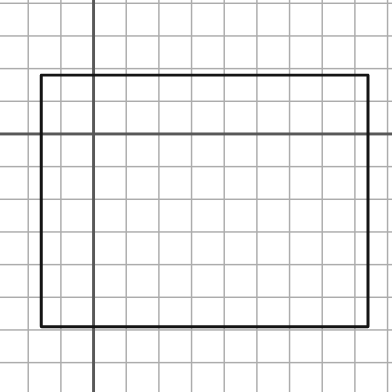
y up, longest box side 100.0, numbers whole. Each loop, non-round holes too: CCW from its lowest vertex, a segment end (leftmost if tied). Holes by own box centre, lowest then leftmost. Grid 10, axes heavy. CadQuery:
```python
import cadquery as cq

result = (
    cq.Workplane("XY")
    .moveTo(-16.0, -59.0)
    .lineTo(84.0, -59.0)
    .lineTo(84.0, 18.0)
    .lineTo(-16.0, 18.0)
    .close()
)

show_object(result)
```